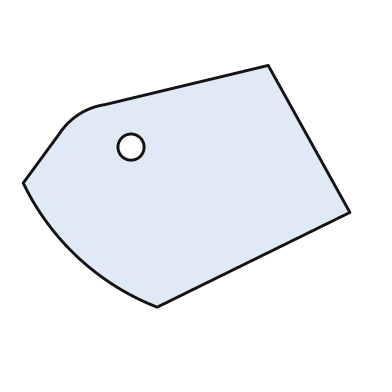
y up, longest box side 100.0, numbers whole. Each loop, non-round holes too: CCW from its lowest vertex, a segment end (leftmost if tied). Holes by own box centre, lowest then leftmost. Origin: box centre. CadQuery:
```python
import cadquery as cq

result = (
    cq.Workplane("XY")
    .moveTo(-9.0, -37.0)
    .lineTo(50.0, -8.0)
    .lineTo(25.0, 37.0)
    .lineTo(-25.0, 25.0)
    .threePointArc((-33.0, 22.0), (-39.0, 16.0))
    .lineTo(-50.0, 1.0)
    .threePointArc((-33.0, -22.0), (-9.0, -37.0))
    .close()
    .moveTo(-17.0, 12.0)
    .circle(4.0)
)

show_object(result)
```